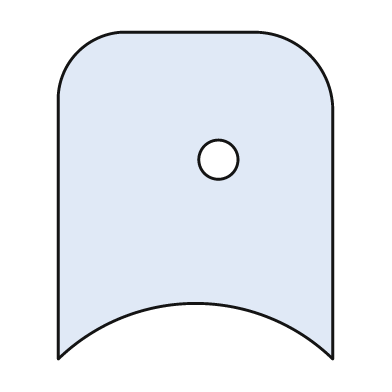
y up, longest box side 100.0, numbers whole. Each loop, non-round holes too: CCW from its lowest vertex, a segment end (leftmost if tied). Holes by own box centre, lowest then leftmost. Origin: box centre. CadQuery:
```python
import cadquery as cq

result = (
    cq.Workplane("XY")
    .moveTo(-42.0, -50.0)
    .threePointArc((0.0, -33.0), (42.0, -50.0))
    .lineTo(42.0, 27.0)
    .threePointArc((35.0, 43.0), (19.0, 50.0))
    .lineTo(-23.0, 50.0)
    .threePointArc((-36.0, 44.0), (-42.0, 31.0))
    .close()
    .moveTo(7.0, 11.0)
    .circle(6.0)
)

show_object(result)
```